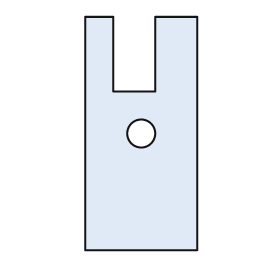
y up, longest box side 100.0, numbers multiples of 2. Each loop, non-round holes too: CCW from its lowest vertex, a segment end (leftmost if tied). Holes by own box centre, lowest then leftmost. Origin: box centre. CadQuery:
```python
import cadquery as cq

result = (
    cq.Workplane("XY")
    .moveTo(-24.0, -50.0)
    .lineTo(24.0, -50.0)
    .lineTo(24.0, 50.0)
    .lineTo(6.0, 50.0)
    .lineTo(6.0, 18.0)
    .lineTo(-12.0, 18.0)
    .lineTo(-12.0, 50.0)
    .lineTo(-24.0, 50.0)
    .close()
    .moveTo(0.0, 0.0)
    .circle(6.0)
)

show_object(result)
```